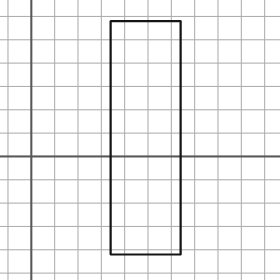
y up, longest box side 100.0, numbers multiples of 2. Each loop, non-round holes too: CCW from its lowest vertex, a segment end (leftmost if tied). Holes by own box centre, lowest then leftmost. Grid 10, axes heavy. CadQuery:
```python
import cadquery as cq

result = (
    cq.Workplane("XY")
    .moveTo(34.0, -42.0)
    .lineTo(64.0, -42.0)
    .lineTo(64.0, 58.0)
    .lineTo(34.0, 58.0)
    .close()
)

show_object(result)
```